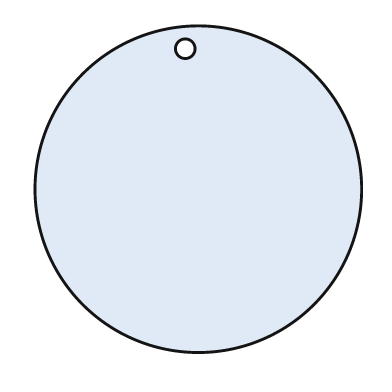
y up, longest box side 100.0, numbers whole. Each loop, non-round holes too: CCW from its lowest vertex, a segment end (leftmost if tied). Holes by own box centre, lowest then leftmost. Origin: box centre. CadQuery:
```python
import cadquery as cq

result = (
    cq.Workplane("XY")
    .moveTo(0.0, 0.0)
    .circle(50.0)
    .moveTo(-4.0, 43.0)
    .circle(3.0)
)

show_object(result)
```